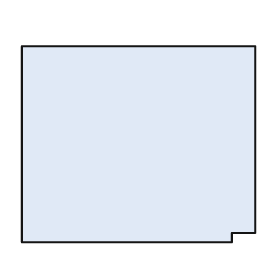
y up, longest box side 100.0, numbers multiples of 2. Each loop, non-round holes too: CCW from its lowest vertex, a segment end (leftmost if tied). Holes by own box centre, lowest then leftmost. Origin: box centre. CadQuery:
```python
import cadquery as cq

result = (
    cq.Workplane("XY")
    .moveTo(-50.0, -42.0)
    .lineTo(40.0, -42.0)
    .lineTo(40.0, -38.0)
    .lineTo(50.0, -38.0)
    .lineTo(50.0, 42.0)
    .lineTo(-50.0, 42.0)
    .close()
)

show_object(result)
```